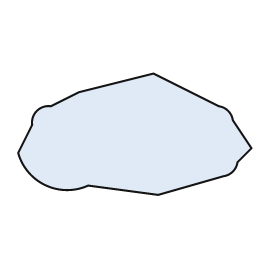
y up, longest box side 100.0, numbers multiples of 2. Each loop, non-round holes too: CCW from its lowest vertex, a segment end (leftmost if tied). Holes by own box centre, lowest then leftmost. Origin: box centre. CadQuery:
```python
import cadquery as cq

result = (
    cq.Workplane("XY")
    .moveTo(10.0, -26.0)
    .lineTo(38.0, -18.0)
    .threePointArc((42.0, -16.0), (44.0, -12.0))
    .lineTo(50.0, -6.0)
    .lineTo(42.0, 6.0)
    .threePointArc((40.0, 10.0), (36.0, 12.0))
    .lineTo(8.0, 26.0)
    .lineTo(-24.0, 18.0)
    .lineTo(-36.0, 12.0)
    .threePointArc((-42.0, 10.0), (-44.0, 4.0))
    .lineTo(-50.0, -8.0)
    .threePointArc((-38.0, -22.0), (-20.0, -22.0))
    .close()
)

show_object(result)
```